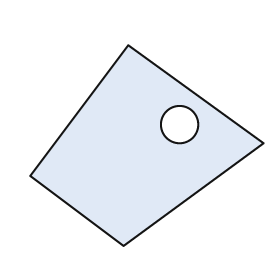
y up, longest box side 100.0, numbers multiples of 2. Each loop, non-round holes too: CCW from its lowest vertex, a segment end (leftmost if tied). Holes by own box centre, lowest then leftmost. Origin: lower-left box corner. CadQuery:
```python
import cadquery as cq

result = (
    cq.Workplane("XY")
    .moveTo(40.0, 0.0)
    .lineTo(100.0, 44.0)
    .lineTo(42.0, 86.0)
    .lineTo(0.0, 30.0)
    .close()
    .moveTo(64.0, 52.0)
    .circle(8.0)
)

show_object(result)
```